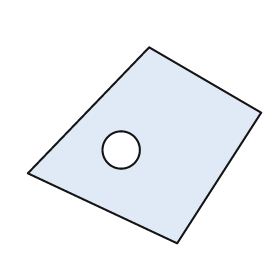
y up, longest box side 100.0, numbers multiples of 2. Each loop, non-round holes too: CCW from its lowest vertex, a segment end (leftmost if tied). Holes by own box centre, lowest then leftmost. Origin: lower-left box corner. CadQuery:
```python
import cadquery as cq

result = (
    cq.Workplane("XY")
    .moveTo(64.0, 0.0)
    .lineTo(100.0, 56.0)
    .lineTo(52.0, 84.0)
    .lineTo(0.0, 30.0)
    .close()
    .moveTo(40.0, 40.0)
    .circle(8.0)
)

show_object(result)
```